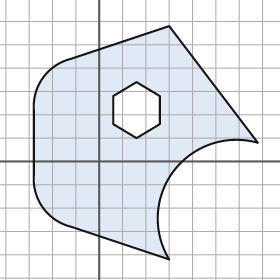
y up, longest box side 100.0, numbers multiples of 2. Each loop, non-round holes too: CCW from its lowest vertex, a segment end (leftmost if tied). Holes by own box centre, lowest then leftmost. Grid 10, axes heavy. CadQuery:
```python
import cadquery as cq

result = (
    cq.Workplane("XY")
    .moveTo(30.0, -42.0)
    .threePointArc((32.0, -4.0), (68.0, 8.0))
    .lineTo(30.0, 58.0)
    .lineTo(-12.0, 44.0)
    .threePointArc((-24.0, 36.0), (-28.0, 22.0))
    .lineTo(-28.0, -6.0)
    .threePointArc((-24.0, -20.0), (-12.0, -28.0))
    .close()
    .moveTo(16.0, 10.0)
    .lineTo(26.0, 16.0)
    .lineTo(26.0, 28.0)
    .lineTo(16.0, 34.0)
    .lineTo(6.0, 28.0)
    .lineTo(6.0, 16.0)
    .close()
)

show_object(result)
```